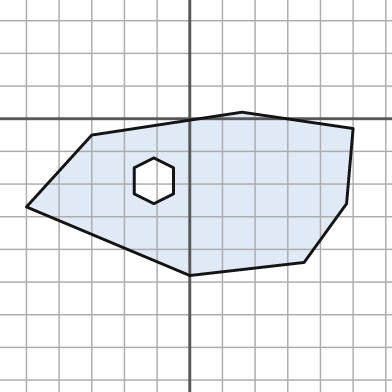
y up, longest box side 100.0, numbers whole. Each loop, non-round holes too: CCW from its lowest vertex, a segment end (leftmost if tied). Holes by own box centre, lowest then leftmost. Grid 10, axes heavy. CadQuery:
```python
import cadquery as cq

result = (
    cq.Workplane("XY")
    .moveTo(0.0, -48.0)
    .lineTo(35.0, -44.0)
    .lineTo(48.0, -26.0)
    .lineTo(50.0, -3.0)
    .lineTo(16.0, 2.0)
    .lineTo(-30.0, -5.0)
    .lineTo(-50.0, -27.0)
    .close()
    .moveTo(-11.0, -26.0)
    .lineTo(-5.0, -23.0)
    .lineTo(-5.0, -15.0)
    .lineTo(-11.0, -12.0)
    .lineTo(-17.0, -15.0)
    .lineTo(-17.0, -23.0)
    .close()
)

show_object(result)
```